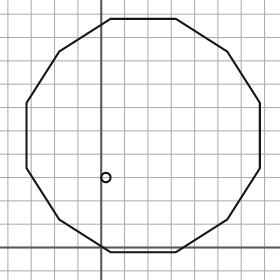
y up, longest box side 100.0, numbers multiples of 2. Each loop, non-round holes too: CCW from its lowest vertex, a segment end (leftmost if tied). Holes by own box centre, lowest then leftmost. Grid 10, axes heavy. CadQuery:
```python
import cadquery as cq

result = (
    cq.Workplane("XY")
    .moveTo(4.0, -2.0)
    .lineTo(32.0, -2.0)
    .lineTo(54.0, 12.0)
    .lineTo(68.0, 34.0)
    .lineTo(68.0, 62.0)
    .lineTo(54.0, 84.0)
    .lineTo(32.0, 98.0)
    .lineTo(4.0, 98.0)
    .lineTo(-18.0, 84.0)
    .lineTo(-32.0, 62.0)
    .lineTo(-32.0, 34.0)
    .lineTo(-18.0, 12.0)
    .close()
    .moveTo(2.0, 30.0)
    .circle(2.0)
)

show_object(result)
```